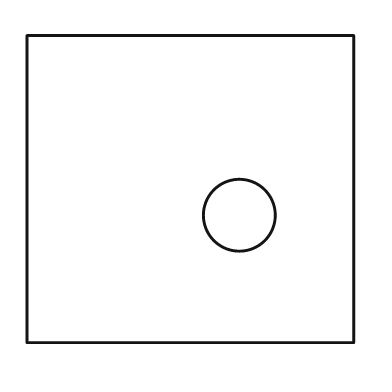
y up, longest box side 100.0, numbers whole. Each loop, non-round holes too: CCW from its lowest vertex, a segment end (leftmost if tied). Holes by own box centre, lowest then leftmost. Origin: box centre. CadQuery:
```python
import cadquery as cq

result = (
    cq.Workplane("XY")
    .moveTo(-50.0, -47.0)
    .lineTo(50.0, -47.0)
    .lineTo(50.0, 47.0)
    .lineTo(-50.0, 47.0)
    .close()
    .moveTo(15.0, -8.0)
    .circle(11.0)
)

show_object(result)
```